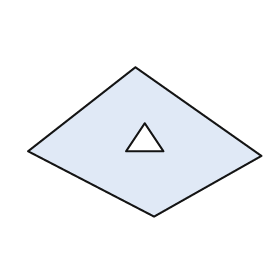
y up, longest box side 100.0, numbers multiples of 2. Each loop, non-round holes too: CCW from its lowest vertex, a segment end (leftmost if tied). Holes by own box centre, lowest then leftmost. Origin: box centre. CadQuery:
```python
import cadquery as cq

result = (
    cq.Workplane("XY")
    .moveTo(4.0, -32.0)
    .lineTo(50.0, -6.0)
    .lineTo(-4.0, 32.0)
    .lineTo(-50.0, -4.0)
    .close()
    .moveTo(-8.0, -4.0)
    .lineTo(8.0, -4.0)
    .lineTo(0.0, 8.0)
    .close()
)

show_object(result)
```